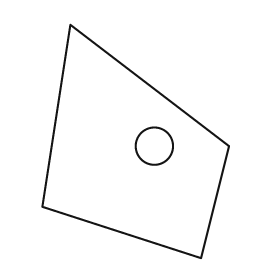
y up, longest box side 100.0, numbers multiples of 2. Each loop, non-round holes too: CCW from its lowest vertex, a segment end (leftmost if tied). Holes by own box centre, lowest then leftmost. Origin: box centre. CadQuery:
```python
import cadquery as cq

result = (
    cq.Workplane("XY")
    .moveTo(28.0, -50.0)
    .lineTo(40.0, -2.0)
    .lineTo(-28.0, 50.0)
    .lineTo(-40.0, -28.0)
    .close()
    .moveTo(8.0, -2.0)
    .circle(8.0)
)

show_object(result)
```